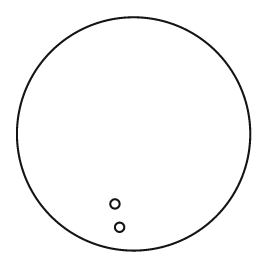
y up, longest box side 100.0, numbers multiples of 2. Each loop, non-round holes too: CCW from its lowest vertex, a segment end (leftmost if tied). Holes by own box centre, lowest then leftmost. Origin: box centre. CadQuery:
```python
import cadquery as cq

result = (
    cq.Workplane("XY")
    .moveTo(0.0, 0.0)
    .circle(50.0)
    .moveTo(-6.0, -40.0)
    .circle(2.0)
    .moveTo(-8.0, -30.0)
    .circle(2.0)
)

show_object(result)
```